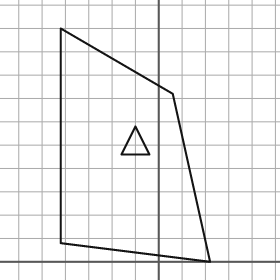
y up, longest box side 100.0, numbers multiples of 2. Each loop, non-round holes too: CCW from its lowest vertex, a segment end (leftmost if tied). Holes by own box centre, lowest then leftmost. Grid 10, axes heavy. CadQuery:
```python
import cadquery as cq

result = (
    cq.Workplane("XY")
    .moveTo(22.0, 0.0)
    .lineTo(6.0, 72.0)
    .lineTo(-42.0, 100.0)
    .lineTo(-42.0, 8.0)
    .close()
    .moveTo(-16.0, 46.0)
    .lineTo(-4.0, 46.0)
    .lineTo(-10.0, 58.0)
    .close()
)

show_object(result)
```